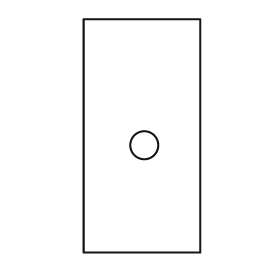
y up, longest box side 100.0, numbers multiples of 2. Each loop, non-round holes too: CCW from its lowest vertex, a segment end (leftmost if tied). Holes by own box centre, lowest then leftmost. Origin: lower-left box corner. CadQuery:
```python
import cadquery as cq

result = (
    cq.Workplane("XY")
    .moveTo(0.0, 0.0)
    .lineTo(50.0, 0.0)
    .lineTo(50.0, 100.0)
    .lineTo(0.0, 100.0)
    .close()
    .moveTo(26.0, 46.0)
    .circle(6.0)
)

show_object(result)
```